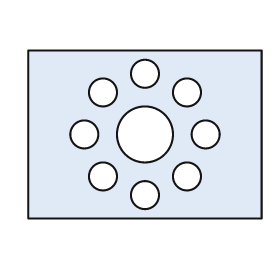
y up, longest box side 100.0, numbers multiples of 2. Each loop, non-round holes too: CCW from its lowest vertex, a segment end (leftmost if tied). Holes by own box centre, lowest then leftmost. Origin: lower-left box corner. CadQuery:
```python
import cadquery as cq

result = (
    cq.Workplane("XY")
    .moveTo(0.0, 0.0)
    .lineTo(100.0, 0.0)
    .lineTo(100.0, 72.0)
    .lineTo(0.0, 72.0)
    .close()
    .moveTo(50.0, 10.0)
    .circle(6.0)
    .moveTo(32.0, 18.0)
    .circle(6.0)
    .moveTo(68.0, 18.0)
    .circle(6.0)
    .moveTo(24.0, 36.0)
    .circle(6.0)
    .moveTo(50.0, 36.0)
    .circle(12.0)
    .moveTo(76.0, 36.0)
    .circle(6.0)
    .moveTo(32.0, 54.0)
    .circle(6.0)
    .moveTo(68.0, 54.0)
    .circle(6.0)
    .moveTo(50.0, 62.0)
    .circle(6.0)
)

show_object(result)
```